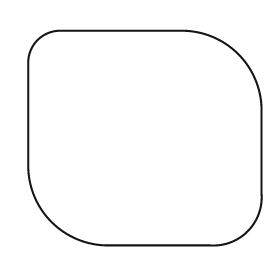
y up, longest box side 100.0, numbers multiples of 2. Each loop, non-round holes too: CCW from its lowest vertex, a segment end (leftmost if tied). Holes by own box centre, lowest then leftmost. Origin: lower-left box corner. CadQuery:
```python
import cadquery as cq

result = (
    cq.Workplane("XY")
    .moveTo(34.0, 0.0)
    .lineTo(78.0, 0.0)
    .threePointArc((94.0, 6.0), (100.0, 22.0))
    .lineTo(100.0, 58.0)
    .threePointArc((90.0, 82.0), (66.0, 92.0))
    .lineTo(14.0, 92.0)
    .threePointArc((4.0, 88.0), (0.0, 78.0))
    .lineTo(0.0, 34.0)
    .threePointArc((10.0, 10.0), (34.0, 0.0))
    .close()
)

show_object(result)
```